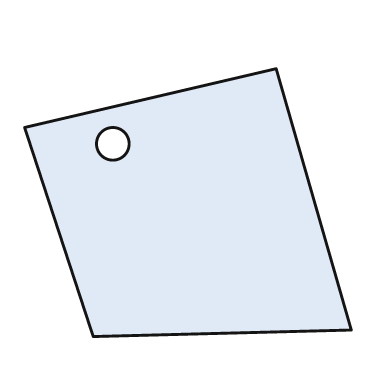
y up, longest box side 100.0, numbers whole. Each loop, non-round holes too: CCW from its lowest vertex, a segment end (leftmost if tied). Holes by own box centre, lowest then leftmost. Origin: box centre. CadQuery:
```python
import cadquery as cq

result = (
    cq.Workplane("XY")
    .moveTo(-29.0, -41.0)
    .lineTo(50.0, -39.0)
    .lineTo(27.0, 41.0)
    .lineTo(-50.0, 23.0)
    .close()
    .moveTo(-23.0, 18.0)
    .circle(5.0)
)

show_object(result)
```